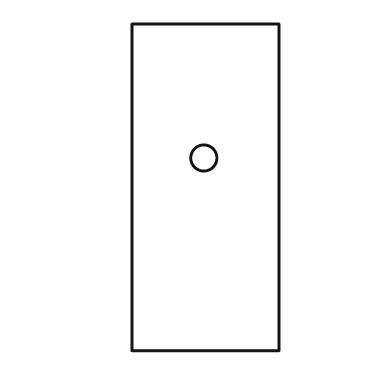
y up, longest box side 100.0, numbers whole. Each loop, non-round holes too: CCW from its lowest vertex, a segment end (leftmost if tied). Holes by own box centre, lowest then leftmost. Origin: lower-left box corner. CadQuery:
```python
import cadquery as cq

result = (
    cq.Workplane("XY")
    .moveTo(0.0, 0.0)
    .lineTo(45.0, 0.0)
    .lineTo(45.0, 100.0)
    .lineTo(0.0, 100.0)
    .close()
    .moveTo(22.0, 59.0)
    .circle(4.0)
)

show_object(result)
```